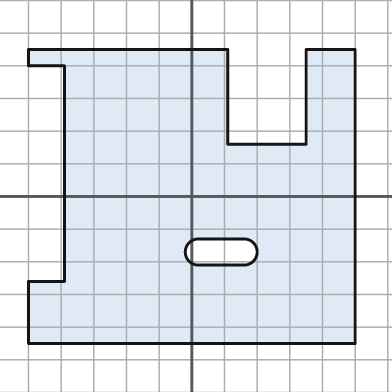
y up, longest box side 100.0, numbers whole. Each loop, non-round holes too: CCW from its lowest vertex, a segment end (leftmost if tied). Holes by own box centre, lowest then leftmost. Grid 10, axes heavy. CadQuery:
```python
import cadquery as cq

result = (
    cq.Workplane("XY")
    .moveTo(-50.0, -45.0)
    .lineTo(50.0, -45.0)
    .lineTo(50.0, 45.0)
    .lineTo(35.0, 45.0)
    .lineTo(35.0, 16.0)
    .lineTo(11.0, 16.0)
    .lineTo(11.0, 45.0)
    .lineTo(-50.0, 45.0)
    .lineTo(-50.0, 40.0)
    .lineTo(-39.0, 40.0)
    .lineTo(-39.0, -26.0)
    .lineTo(-50.0, -26.0)
    .close()
    .moveTo(2.0, -21.0)
    .lineTo(16.0, -21.0)
    .threePointArc((20.0, -17.0), (16.0, -13.0))
    .lineTo(2.0, -13.0)
    .threePointArc((-2.0, -17.0), (2.0, -21.0))
    .close()
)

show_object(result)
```